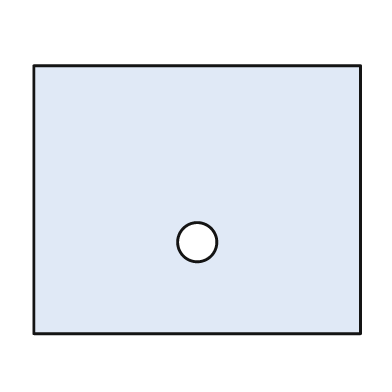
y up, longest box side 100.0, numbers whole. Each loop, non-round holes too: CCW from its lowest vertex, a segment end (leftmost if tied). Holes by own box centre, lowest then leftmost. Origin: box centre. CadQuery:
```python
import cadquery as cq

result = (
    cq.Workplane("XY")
    .moveTo(-50.0, -41.0)
    .lineTo(50.0, -41.0)
    .lineTo(50.0, 41.0)
    .lineTo(-50.0, 41.0)
    .close()
    .moveTo(0.0, -13.0)
    .circle(6.0)
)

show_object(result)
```